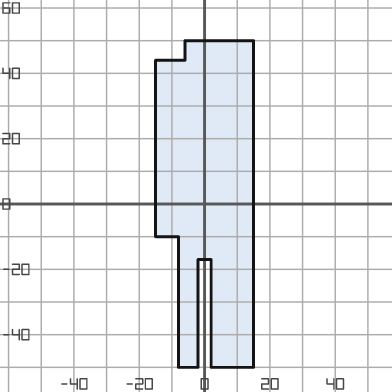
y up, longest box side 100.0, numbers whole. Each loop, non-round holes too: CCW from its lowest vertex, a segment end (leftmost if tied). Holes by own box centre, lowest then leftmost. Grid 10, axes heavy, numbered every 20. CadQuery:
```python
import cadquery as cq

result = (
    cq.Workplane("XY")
    .moveTo(-8.0, -50.0)
    .lineTo(-2.0, -50.0)
    .lineTo(-2.0, -17.0)
    .lineTo(2.0, -17.0)
    .lineTo(2.0, -50.0)
    .lineTo(15.0, -50.0)
    .lineTo(15.0, 50.0)
    .lineTo(-6.0, 50.0)
    .lineTo(-6.0, 44.0)
    .lineTo(-15.0, 44.0)
    .lineTo(-15.0, -10.0)
    .lineTo(-8.0, -10.0)
    .close()
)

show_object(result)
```